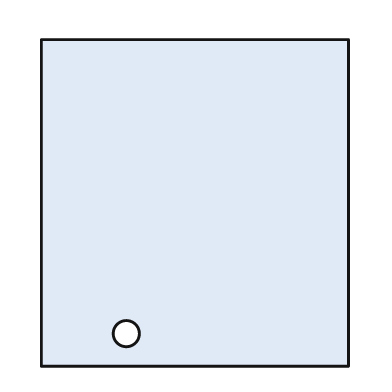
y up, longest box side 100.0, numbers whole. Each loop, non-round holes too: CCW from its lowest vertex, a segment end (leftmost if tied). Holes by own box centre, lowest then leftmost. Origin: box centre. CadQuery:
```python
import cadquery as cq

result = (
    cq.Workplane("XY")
    .moveTo(-47.0, -50.0)
    .lineTo(47.0, -50.0)
    .lineTo(47.0, 50.0)
    .lineTo(-47.0, 50.0)
    .close()
    .moveTo(-21.0, -40.0)
    .circle(4.0)
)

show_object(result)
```